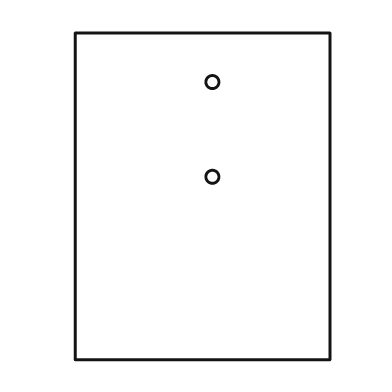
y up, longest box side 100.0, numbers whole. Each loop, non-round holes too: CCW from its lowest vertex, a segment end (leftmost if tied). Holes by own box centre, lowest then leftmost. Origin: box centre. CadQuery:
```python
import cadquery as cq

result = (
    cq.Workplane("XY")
    .moveTo(-39.0, -50.0)
    .lineTo(39.0, -50.0)
    .lineTo(39.0, 50.0)
    .lineTo(-39.0, 50.0)
    .close()
    .moveTo(3.0, 6.0)
    .circle(2.0)
    .moveTo(3.0, 35.0)
    .circle(2.0)
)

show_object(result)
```